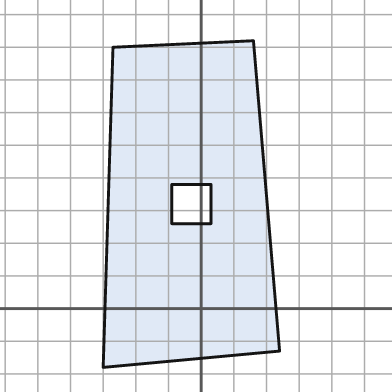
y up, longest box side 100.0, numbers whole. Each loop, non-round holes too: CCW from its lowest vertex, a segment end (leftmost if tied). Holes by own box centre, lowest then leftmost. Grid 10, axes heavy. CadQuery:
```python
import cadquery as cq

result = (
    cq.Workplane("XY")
    .moveTo(-30.0, -18.0)
    .lineTo(24.0, -13.0)
    .lineTo(16.0, 82.0)
    .lineTo(-27.0, 80.0)
    .close()
    .moveTo(-9.0, 26.0)
    .lineTo(3.0, 26.0)
    .lineTo(3.0, 38.0)
    .lineTo(-9.0, 38.0)
    .close()
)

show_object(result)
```